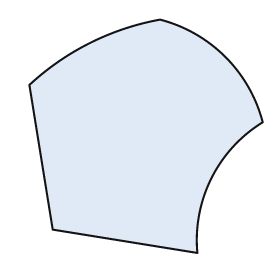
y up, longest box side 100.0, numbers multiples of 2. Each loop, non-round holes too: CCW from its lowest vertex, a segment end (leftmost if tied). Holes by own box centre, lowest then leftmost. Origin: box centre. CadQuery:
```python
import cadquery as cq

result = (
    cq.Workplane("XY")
    .moveTo(22.0, -50.0)
    .threePointArc((28.0, -18.0), (50.0, 6.0))
    .threePointArc((34.0, 34.0), (6.0, 50.0))
    .threePointArc((-24.0, 40.0), (-50.0, 22.0))
    .lineTo(-40.0, -40.0)
    .close()
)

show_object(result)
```